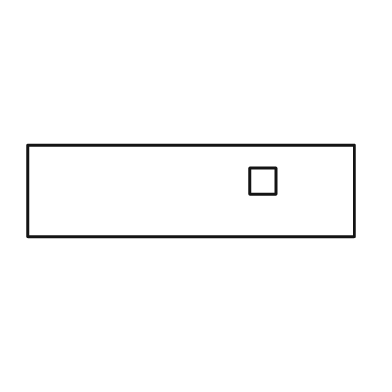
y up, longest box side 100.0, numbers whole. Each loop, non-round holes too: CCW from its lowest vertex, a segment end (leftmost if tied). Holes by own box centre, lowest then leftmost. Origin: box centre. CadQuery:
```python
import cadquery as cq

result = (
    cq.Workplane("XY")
    .moveTo(-50.0, -14.0)
    .lineTo(50.0, -14.0)
    .lineTo(50.0, 14.0)
    .lineTo(-50.0, 14.0)
    .close()
    .moveTo(18.0, -1.0)
    .lineTo(26.0, -1.0)
    .lineTo(26.0, 7.0)
    .lineTo(18.0, 7.0)
    .close()
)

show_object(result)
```